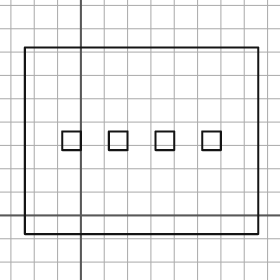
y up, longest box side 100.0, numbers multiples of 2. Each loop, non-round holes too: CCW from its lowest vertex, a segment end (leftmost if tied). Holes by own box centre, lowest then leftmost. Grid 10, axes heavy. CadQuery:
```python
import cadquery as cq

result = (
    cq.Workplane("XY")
    .moveTo(-24.0, -8.0)
    .lineTo(76.0, -8.0)
    .lineTo(76.0, 72.0)
    .lineTo(-24.0, 72.0)
    .close()
    .moveTo(-8.0, 28.0)
    .lineTo(0.0, 28.0)
    .lineTo(0.0, 36.0)
    .lineTo(-8.0, 36.0)
    .close()
    .moveTo(12.0, 28.0)
    .lineTo(20.0, 28.0)
    .lineTo(20.0, 36.0)
    .lineTo(12.0, 36.0)
    .close()
    .moveTo(32.0, 28.0)
    .lineTo(40.0, 28.0)
    .lineTo(40.0, 36.0)
    .lineTo(32.0, 36.0)
    .close()
    .moveTo(52.0, 28.0)
    .lineTo(60.0, 28.0)
    .lineTo(60.0, 36.0)
    .lineTo(52.0, 36.0)
    .close()
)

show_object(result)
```